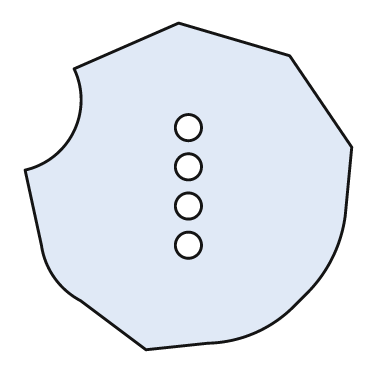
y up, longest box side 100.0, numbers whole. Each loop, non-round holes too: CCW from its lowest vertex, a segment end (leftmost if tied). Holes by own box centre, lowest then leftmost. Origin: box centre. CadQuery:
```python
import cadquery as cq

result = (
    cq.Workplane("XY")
    .moveTo(-13.0, -50.0)
    .lineTo(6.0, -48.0)
    .threePointArc((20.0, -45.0), (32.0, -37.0))
    .lineTo(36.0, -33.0)
    .threePointArc((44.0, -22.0), (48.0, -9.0))
    .lineTo(50.0, 12.0)
    .lineTo(31.0, 40.0)
    .lineTo(-3.0, 50.0)
    .lineTo(-35.0, 36.0)
    .threePointArc((-35.0, 17.0), (-50.0, 5.0))
    .lineTo(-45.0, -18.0)
    .threePointArc((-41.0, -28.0), (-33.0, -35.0))
    .close()
    .moveTo(0.0, -18.0)
    .circle(4.0)
    .moveTo(0.0, -6.0)
    .circle(4.0)
    .moveTo(0.0, 6.0)
    .circle(4.0)
    .moveTo(0.0, 18.0)
    .circle(4.0)
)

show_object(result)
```